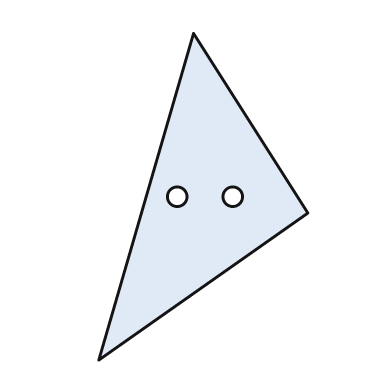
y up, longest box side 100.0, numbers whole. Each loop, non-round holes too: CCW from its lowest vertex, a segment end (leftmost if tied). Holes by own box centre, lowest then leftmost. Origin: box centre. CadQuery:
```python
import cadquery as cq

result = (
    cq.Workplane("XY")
    .moveTo(-32.0, -50.0)
    .lineTo(32.0, -5.0)
    .lineTo(-3.0, 50.0)
    .close()
    .moveTo(-8.0, 0.0)
    .circle(3.0)
    .moveTo(9.0, 0.0)
    .circle(3.0)
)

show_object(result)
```